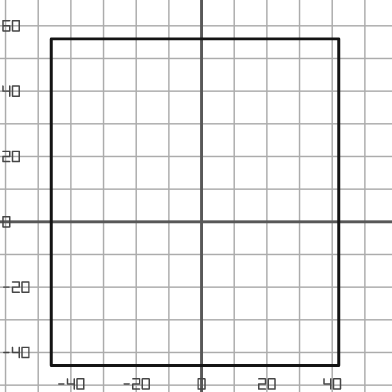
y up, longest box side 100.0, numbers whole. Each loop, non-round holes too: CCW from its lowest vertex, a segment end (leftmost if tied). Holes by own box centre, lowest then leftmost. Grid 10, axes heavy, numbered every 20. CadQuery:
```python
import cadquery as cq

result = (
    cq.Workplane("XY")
    .moveTo(-46.0, -44.0)
    .lineTo(42.0, -44.0)
    .lineTo(42.0, 56.0)
    .lineTo(-46.0, 56.0)
    .close()
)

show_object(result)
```